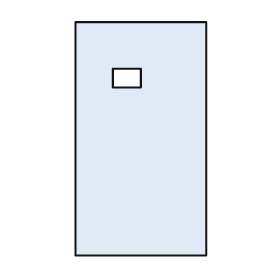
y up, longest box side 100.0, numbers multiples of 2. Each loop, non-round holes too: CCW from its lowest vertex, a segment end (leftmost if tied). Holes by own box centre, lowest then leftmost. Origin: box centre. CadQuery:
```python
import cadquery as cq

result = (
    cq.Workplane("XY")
    .moveTo(-28.0, -50.0)
    .lineTo(28.0, -50.0)
    .lineTo(28.0, 50.0)
    .lineTo(-28.0, 50.0)
    .close()
    .moveTo(-12.0, 22.0)
    .lineTo(0.0, 22.0)
    .lineTo(0.0, 30.0)
    .lineTo(-12.0, 30.0)
    .close()
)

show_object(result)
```